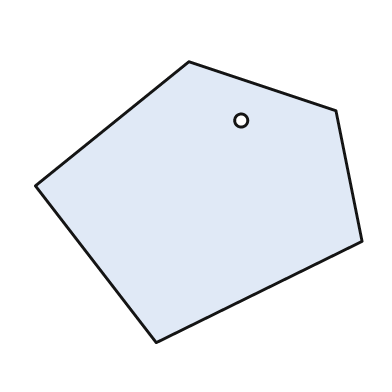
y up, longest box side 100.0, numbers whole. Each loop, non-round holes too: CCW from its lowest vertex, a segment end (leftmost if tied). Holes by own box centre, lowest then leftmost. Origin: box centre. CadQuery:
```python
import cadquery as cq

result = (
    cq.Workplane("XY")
    .moveTo(-13.0, -43.0)
    .lineTo(50.0, -12.0)
    .lineTo(42.0, 28.0)
    .lineTo(-3.0, 43.0)
    .lineTo(-50.0, 5.0)
    .close()
    .moveTo(13.0, 25.0)
    .circle(2.0)
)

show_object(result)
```